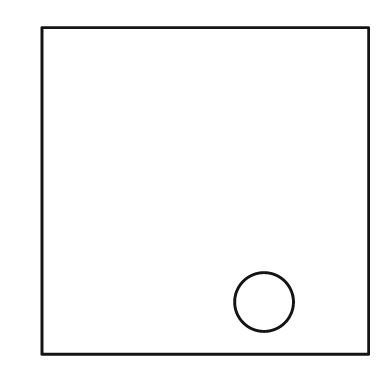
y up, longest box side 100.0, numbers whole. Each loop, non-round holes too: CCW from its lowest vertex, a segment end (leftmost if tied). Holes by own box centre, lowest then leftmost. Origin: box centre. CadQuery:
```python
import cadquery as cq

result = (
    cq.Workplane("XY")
    .moveTo(-50.0, -50.0)
    .lineTo(50.0, -50.0)
    .lineTo(50.0, 50.0)
    .lineTo(-50.0, 50.0)
    .close()
    .moveTo(18.0, -34.0)
    .circle(9.0)
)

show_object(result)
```